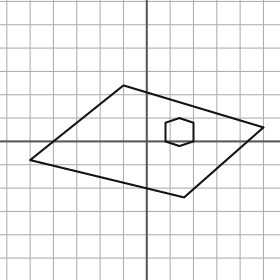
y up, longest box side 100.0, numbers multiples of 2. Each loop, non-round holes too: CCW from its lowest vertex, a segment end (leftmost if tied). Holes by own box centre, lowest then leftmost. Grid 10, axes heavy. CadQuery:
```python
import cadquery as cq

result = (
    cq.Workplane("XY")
    .moveTo(16.0, -24.0)
    .lineTo(50.0, 6.0)
    .lineTo(-10.0, 24.0)
    .lineTo(-50.0, -8.0)
    .close()
    .moveTo(14.0, -2.0)
    .lineTo(20.0, 0.0)
    .lineTo(20.0, 8.0)
    .lineTo(14.0, 10.0)
    .lineTo(8.0, 8.0)
    .lineTo(8.0, 0.0)
    .close()
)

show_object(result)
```